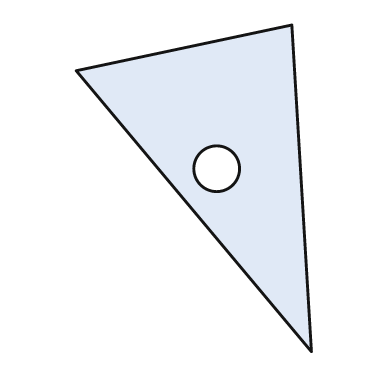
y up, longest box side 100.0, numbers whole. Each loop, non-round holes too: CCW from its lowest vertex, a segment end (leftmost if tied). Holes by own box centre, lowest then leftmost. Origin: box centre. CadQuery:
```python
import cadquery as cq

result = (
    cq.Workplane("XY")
    .moveTo(36.0, -50.0)
    .lineTo(30.0, 50.0)
    .lineTo(-36.0, 36.0)
    .close()
    .moveTo(7.0, 6.0)
    .circle(7.0)
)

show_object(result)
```